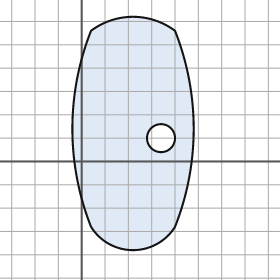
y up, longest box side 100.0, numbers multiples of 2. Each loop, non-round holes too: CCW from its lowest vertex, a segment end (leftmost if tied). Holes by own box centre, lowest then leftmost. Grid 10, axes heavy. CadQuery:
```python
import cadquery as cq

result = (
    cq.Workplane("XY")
    .moveTo(4.0, -28.0)
    .threePointArc((22.0, -38.0), (40.0, -28.0))
    .threePointArc((48.0, 14.0), (40.0, 56.0))
    .threePointArc((22.0, 62.0), (4.0, 56.0))
    .threePointArc((-4.0, 14.0), (4.0, -28.0))
    .close()
    .moveTo(34.0, 10.0)
    .circle(6.0)
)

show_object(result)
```